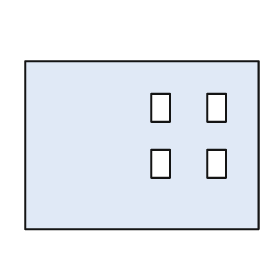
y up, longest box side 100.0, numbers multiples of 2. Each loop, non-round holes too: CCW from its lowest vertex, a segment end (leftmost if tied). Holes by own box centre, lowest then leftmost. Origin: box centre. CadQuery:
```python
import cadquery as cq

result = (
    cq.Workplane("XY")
    .moveTo(-50.0, -36.0)
    .lineTo(50.0, -36.0)
    .lineTo(50.0, 36.0)
    .lineTo(-50.0, 36.0)
    .close()
    .moveTo(4.0, -14.0)
    .lineTo(12.0, -14.0)
    .lineTo(12.0, -2.0)
    .lineTo(4.0, -2.0)
    .close()
    .moveTo(28.0, -14.0)
    .lineTo(36.0, -14.0)
    .lineTo(36.0, -2.0)
    .lineTo(28.0, -2.0)
    .close()
    .moveTo(4.0, 10.0)
    .lineTo(12.0, 10.0)
    .lineTo(12.0, 22.0)
    .lineTo(4.0, 22.0)
    .close()
    .moveTo(28.0, 10.0)
    .lineTo(36.0, 10.0)
    .lineTo(36.0, 22.0)
    .lineTo(28.0, 22.0)
    .close()
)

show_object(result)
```